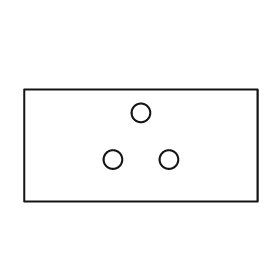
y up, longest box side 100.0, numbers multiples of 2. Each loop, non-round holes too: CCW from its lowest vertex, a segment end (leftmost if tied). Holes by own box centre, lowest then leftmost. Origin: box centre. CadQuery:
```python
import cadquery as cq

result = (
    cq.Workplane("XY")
    .moveTo(-50.0, -24.0)
    .lineTo(50.0, -24.0)
    .lineTo(50.0, 24.0)
    .lineTo(-50.0, 24.0)
    .close()
    .moveTo(-12.0, -6.0)
    .circle(4.0)
    .moveTo(12.0, -6.0)
    .circle(4.0)
    .moveTo(0.0, 14.0)
    .circle(4.0)
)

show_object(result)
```